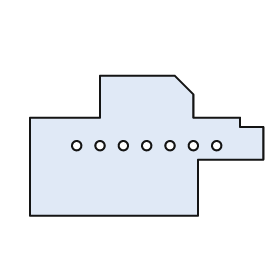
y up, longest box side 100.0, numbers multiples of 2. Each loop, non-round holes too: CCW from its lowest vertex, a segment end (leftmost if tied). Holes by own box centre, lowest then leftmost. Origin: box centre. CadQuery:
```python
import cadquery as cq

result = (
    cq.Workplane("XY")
    .moveTo(-50.0, -30.0)
    .lineTo(22.0, -30.0)
    .lineTo(22.0, -6.0)
    .lineTo(50.0, -6.0)
    .lineTo(50.0, 8.0)
    .lineTo(40.0, 8.0)
    .lineTo(40.0, 12.0)
    .lineTo(20.0, 12.0)
    .lineTo(20.0, 22.0)
    .lineTo(12.0, 30.0)
    .lineTo(-20.0, 30.0)
    .lineTo(-20.0, 12.0)
    .lineTo(-50.0, 12.0)
    .close()
    .moveTo(-30.0, 0.0)
    .circle(2.0)
    .moveTo(-20.0, 0.0)
    .circle(2.0)
    .moveTo(-10.0, 0.0)
    .circle(2.0)
    .moveTo(0.0, 0.0)
    .circle(2.0)
    .moveTo(10.0, 0.0)
    .circle(2.0)
    .moveTo(20.0, 0.0)
    .circle(2.0)
    .moveTo(30.0, 0.0)
    .circle(2.0)
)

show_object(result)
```